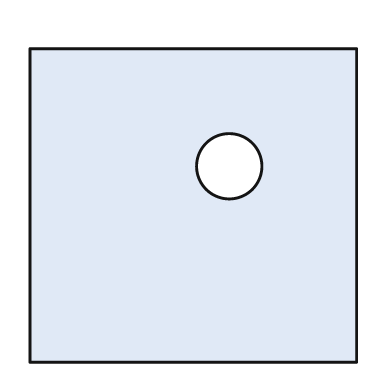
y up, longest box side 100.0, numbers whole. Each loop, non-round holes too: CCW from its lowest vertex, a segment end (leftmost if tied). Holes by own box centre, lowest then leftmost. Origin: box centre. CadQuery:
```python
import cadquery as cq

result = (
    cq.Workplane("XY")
    .moveTo(-50.0, -48.0)
    .lineTo(50.0, -48.0)
    .lineTo(50.0, 48.0)
    .lineTo(-50.0, 48.0)
    .close()
    .moveTo(11.0, 12.0)
    .circle(10.0)
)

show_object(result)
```